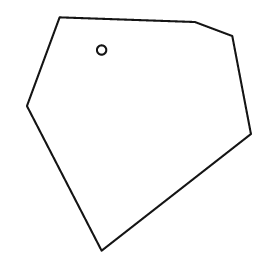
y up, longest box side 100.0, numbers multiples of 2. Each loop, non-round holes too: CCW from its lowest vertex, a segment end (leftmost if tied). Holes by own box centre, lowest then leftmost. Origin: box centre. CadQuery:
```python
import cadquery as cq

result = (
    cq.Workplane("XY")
    .moveTo(-16.0, -50.0)
    .lineTo(48.0, 0.0)
    .lineTo(40.0, 42.0)
    .lineTo(24.0, 48.0)
    .lineTo(-34.0, 50.0)
    .lineTo(-48.0, 12.0)
    .close()
    .moveTo(-16.0, 36.0)
    .circle(2.0)
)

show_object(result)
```